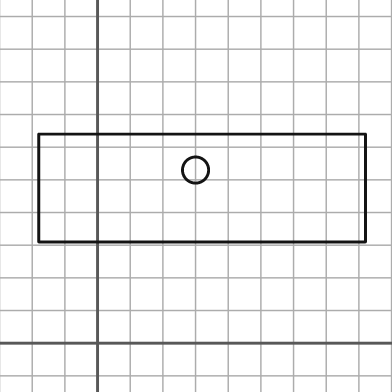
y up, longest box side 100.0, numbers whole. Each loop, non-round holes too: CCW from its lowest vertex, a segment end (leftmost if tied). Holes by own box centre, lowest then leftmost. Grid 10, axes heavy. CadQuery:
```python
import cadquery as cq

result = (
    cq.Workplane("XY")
    .moveTo(-18.0, 31.0)
    .lineTo(82.0, 31.0)
    .lineTo(82.0, 64.0)
    .lineTo(-18.0, 64.0)
    .close()
    .moveTo(30.0, 53.0)
    .circle(4.0)
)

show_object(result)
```